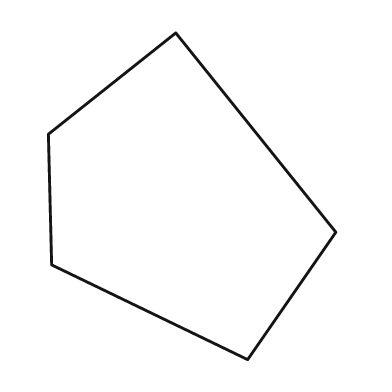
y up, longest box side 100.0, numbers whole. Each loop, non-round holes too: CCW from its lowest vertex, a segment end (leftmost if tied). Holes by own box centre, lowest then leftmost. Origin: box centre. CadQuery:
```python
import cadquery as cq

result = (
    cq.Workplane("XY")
    .moveTo(17.0, -50.0)
    .lineTo(44.0, -11.0)
    .lineTo(-5.0, 50.0)
    .lineTo(-44.0, 19.0)
    .lineTo(-43.0, -21.0)
    .close()
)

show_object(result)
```